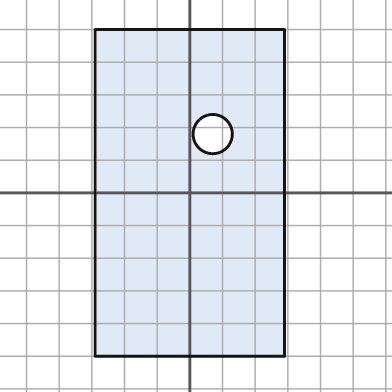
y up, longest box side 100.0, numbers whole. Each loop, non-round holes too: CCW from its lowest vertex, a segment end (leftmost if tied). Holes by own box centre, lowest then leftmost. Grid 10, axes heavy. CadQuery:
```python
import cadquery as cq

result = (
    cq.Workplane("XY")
    .moveTo(-29.0, -50.0)
    .lineTo(29.0, -50.0)
    .lineTo(29.0, 50.0)
    .lineTo(-29.0, 50.0)
    .close()
    .moveTo(7.0, 18.0)
    .circle(6.0)
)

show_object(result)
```